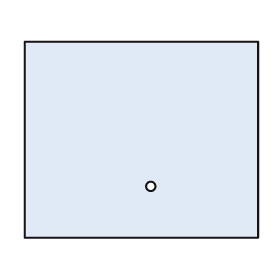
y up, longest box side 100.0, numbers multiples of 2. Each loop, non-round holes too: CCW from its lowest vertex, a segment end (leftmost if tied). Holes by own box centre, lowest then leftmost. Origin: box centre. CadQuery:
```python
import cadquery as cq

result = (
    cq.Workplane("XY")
    .moveTo(-50.0, -42.0)
    .lineTo(50.0, -42.0)
    .lineTo(50.0, 42.0)
    .lineTo(-50.0, 42.0)
    .close()
    .moveTo(4.0, -20.0)
    .circle(2.0)
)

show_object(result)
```